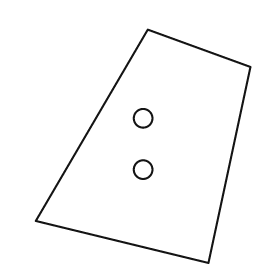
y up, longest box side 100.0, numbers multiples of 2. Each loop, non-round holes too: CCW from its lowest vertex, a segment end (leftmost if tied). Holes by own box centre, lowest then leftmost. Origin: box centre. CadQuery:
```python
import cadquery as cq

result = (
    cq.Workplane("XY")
    .moveTo(28.0, -50.0)
    .lineTo(46.0, 34.0)
    .lineTo(2.0, 50.0)
    .lineTo(-46.0, -32.0)
    .close()
    .moveTo(0.0, -10.0)
    .circle(4.0)
    .moveTo(0.0, 12.0)
    .circle(4.0)
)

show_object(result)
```